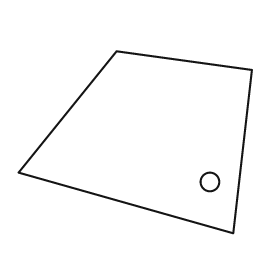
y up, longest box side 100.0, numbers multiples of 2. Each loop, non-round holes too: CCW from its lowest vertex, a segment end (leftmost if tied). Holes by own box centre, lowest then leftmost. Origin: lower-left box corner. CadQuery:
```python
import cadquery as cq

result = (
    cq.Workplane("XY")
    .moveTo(92.0, 0.0)
    .lineTo(100.0, 70.0)
    .lineTo(42.0, 78.0)
    .lineTo(0.0, 26.0)
    .close()
    .moveTo(82.0, 22.0)
    .circle(4.0)
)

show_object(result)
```